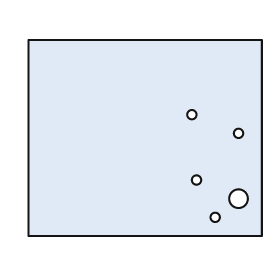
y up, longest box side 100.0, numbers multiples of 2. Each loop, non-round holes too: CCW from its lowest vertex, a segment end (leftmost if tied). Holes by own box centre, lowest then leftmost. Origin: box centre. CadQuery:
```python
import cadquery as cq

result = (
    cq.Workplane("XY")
    .moveTo(-50.0, -42.0)
    .lineTo(50.0, -42.0)
    .lineTo(50.0, 42.0)
    .lineTo(-50.0, 42.0)
    .close()
    .moveTo(30.0, -34.0)
    .circle(2.0)
    .moveTo(40.0, -26.0)
    .circle(4.0)
    .moveTo(22.0, -18.0)
    .circle(2.0)
    .moveTo(40.0, 2.0)
    .circle(2.0)
    .moveTo(20.0, 10.0)
    .circle(2.0)
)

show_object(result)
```